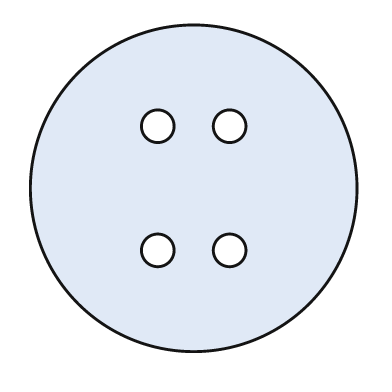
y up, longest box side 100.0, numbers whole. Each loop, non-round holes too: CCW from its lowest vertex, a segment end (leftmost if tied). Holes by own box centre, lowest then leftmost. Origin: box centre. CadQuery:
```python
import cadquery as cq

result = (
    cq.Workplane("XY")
    .moveTo(0.0, 0.0)
    .circle(50.0)
    .moveTo(-11.0, -19.0)
    .circle(5.0)
    .moveTo(11.0, -19.0)
    .circle(5.0)
    .moveTo(-11.0, 19.0)
    .circle(5.0)
    .moveTo(11.0, 19.0)
    .circle(5.0)
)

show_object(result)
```